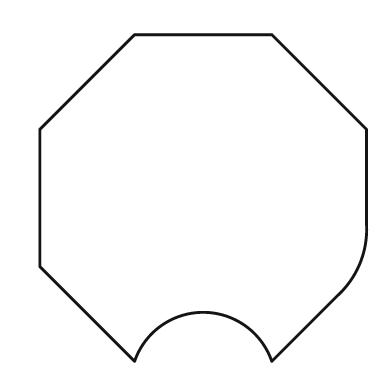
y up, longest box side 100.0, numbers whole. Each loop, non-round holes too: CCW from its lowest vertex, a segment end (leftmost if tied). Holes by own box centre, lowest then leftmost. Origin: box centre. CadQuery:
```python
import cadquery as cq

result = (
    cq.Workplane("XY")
    .moveTo(-21.0, -50.0)
    .threePointArc((0.0, -35.0), (21.0, -50.0))
    .lineTo(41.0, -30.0)
    .threePointArc((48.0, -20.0), (50.0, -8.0))
    .lineTo(50.0, 21.0)
    .lineTo(21.0, 50.0)
    .lineTo(-21.0, 50.0)
    .lineTo(-50.0, 21.0)
    .lineTo(-50.0, -21.0)
    .close()
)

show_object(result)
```